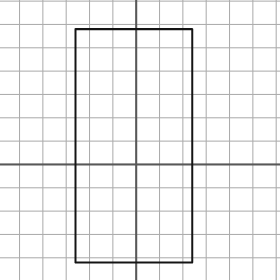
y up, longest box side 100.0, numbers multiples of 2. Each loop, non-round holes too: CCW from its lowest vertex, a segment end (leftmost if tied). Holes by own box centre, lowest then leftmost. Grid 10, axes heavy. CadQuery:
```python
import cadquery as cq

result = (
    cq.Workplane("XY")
    .moveTo(-26.0, -42.0)
    .lineTo(24.0, -42.0)
    .lineTo(24.0, 58.0)
    .lineTo(-26.0, 58.0)
    .close()
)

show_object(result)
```